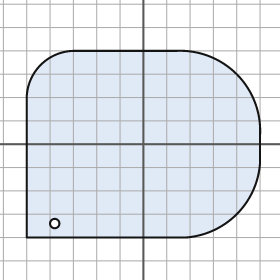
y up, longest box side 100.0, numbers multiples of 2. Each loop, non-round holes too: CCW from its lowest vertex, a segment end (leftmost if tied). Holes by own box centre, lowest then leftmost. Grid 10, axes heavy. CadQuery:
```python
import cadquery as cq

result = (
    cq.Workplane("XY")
    .moveTo(-50.0, -40.0)
    .lineTo(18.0, -40.0)
    .threePointArc((40.0, -30.0), (50.0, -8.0))
    .lineTo(50.0, 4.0)
    .threePointArc((40.0, 30.0), (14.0, 40.0))
    .lineTo(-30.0, 40.0)
    .threePointArc((-44.0, 34.0), (-50.0, 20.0))
    .close()
    .moveTo(-38.0, -34.0)
    .circle(2.0)
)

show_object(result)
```